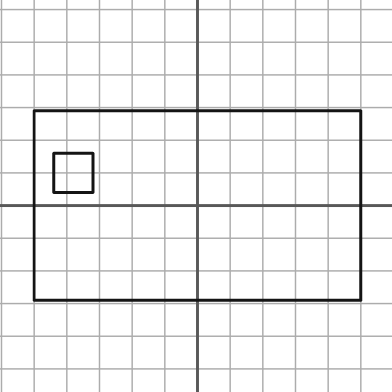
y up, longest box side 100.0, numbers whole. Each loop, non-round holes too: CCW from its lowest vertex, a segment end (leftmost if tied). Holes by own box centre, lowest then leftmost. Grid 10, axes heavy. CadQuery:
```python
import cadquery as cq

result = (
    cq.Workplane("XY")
    .moveTo(-50.0, -29.0)
    .lineTo(50.0, -29.0)
    .lineTo(50.0, 29.0)
    .lineTo(-50.0, 29.0)
    .close()
    .moveTo(-44.0, 4.0)
    .lineTo(-32.0, 4.0)
    .lineTo(-32.0, 16.0)
    .lineTo(-44.0, 16.0)
    .close()
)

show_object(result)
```